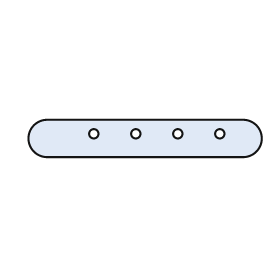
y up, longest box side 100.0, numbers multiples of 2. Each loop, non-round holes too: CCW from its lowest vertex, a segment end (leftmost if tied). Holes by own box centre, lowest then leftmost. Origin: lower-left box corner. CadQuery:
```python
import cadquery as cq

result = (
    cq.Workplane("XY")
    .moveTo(8.0, 0.0)
    .lineTo(92.0, 0.0)
    .threePointArc((100.0, 8.0), (92.0, 16.0))
    .lineTo(8.0, 16.0)
    .threePointArc((0.0, 8.0), (8.0, 0.0))
    .close()
    .moveTo(28.0, 10.0)
    .circle(2.0)
    .moveTo(46.0, 10.0)
    .circle(2.0)
    .moveTo(64.0, 10.0)
    .circle(2.0)
    .moveTo(82.0, 10.0)
    .circle(2.0)
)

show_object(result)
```